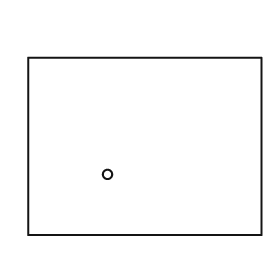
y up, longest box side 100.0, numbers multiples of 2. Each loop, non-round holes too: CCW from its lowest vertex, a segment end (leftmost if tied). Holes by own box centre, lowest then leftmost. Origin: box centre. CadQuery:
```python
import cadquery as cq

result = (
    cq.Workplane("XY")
    .moveTo(-50.0, -38.0)
    .lineTo(50.0, -38.0)
    .lineTo(50.0, 38.0)
    .lineTo(-50.0, 38.0)
    .close()
    .moveTo(-16.0, -12.0)
    .circle(2.0)
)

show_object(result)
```